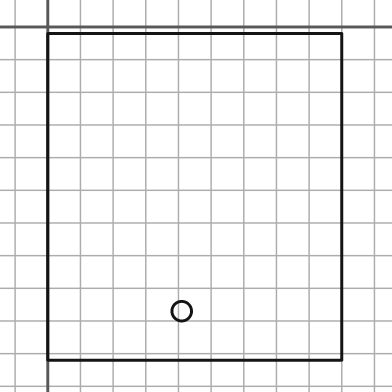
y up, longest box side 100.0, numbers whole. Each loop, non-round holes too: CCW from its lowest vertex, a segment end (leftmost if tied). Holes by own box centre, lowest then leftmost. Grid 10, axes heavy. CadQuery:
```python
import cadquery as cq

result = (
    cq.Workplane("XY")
    .moveTo(0.0, -102.0)
    .lineTo(90.0, -102.0)
    .lineTo(90.0, -2.0)
    .lineTo(0.0, -2.0)
    .close()
    .moveTo(41.0, -87.0)
    .circle(3.0)
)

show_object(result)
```